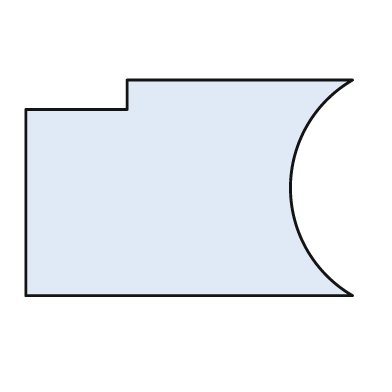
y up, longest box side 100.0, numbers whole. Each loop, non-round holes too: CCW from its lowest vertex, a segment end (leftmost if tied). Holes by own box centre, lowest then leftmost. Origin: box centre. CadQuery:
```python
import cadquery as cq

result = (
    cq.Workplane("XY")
    .moveTo(-50.0, -33.0)
    .lineTo(50.0, -33.0)
    .threePointArc((31.0, 0.0), (50.0, 33.0))
    .lineTo(-19.0, 33.0)
    .lineTo(-19.0, 24.0)
    .lineTo(-50.0, 24.0)
    .close()
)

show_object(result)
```